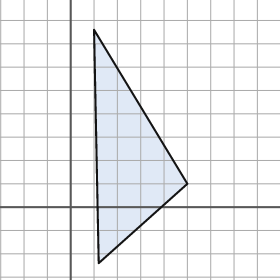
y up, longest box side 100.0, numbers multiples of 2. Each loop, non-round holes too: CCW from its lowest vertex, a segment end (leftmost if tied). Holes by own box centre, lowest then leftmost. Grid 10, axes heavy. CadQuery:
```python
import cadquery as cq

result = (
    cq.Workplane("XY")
    .moveTo(12.0, -24.0)
    .lineTo(50.0, 10.0)
    .lineTo(10.0, 76.0)
    .close()
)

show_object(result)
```